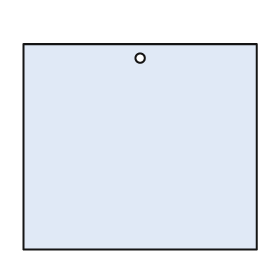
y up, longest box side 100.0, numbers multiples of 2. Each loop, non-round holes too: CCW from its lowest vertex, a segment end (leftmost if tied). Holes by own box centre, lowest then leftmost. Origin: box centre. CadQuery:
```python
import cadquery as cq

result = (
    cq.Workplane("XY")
    .moveTo(-50.0, -44.0)
    .lineTo(50.0, -44.0)
    .lineTo(50.0, 44.0)
    .lineTo(-50.0, 44.0)
    .close()
    .moveTo(0.0, 38.0)
    .circle(2.0)
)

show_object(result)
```